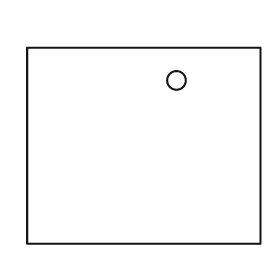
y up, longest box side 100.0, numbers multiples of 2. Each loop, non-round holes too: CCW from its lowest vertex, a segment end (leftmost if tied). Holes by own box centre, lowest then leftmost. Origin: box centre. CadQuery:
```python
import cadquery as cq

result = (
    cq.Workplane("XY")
    .moveTo(-50.0, -42.0)
    .lineTo(50.0, -42.0)
    .lineTo(50.0, 42.0)
    .lineTo(-50.0, 42.0)
    .close()
    .moveTo(14.0, 28.0)
    .circle(4.0)
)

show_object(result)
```